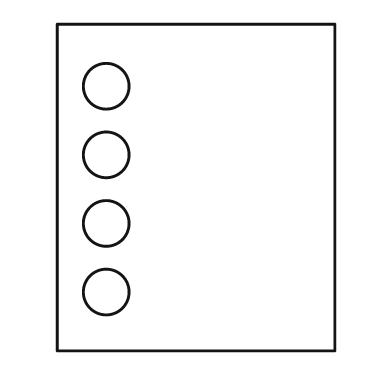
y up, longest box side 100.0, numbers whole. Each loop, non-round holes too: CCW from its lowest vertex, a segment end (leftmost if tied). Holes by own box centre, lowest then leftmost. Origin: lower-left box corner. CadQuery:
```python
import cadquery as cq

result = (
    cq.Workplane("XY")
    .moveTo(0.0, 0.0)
    .lineTo(85.0, 0.0)
    .lineTo(85.0, 100.0)
    .lineTo(0.0, 100.0)
    .close()
    .moveTo(15.0, 18.0)
    .circle(7.0)
    .moveTo(15.0, 39.0)
    .circle(7.0)
    .moveTo(15.0, 60.0)
    .circle(7.0)
    .moveTo(15.0, 81.0)
    .circle(7.0)
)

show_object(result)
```